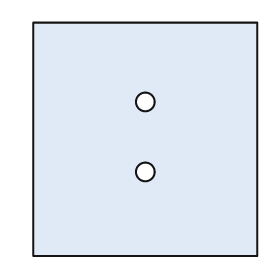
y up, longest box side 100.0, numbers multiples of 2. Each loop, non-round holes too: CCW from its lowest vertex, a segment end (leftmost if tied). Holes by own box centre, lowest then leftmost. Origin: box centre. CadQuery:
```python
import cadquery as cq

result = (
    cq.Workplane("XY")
    .moveTo(-48.0, -50.0)
    .lineTo(48.0, -50.0)
    .lineTo(48.0, 50.0)
    .lineTo(-48.0, 50.0)
    .close()
    .moveTo(0.0, -14.0)
    .circle(4.0)
    .moveTo(0.0, 16.0)
    .circle(4.0)
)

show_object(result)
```